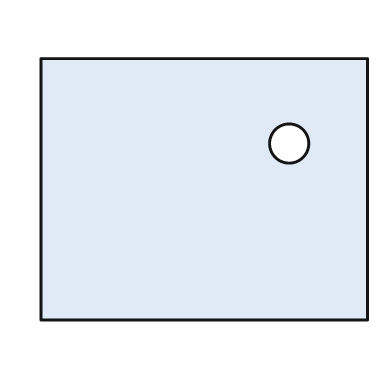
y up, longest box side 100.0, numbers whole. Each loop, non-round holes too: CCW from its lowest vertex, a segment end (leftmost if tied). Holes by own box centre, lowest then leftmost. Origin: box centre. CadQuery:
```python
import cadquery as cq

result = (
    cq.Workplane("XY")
    .moveTo(-50.0, -40.0)
    .lineTo(50.0, -40.0)
    .lineTo(50.0, 40.0)
    .lineTo(-50.0, 40.0)
    .close()
    .moveTo(26.0, 14.0)
    .circle(6.0)
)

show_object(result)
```